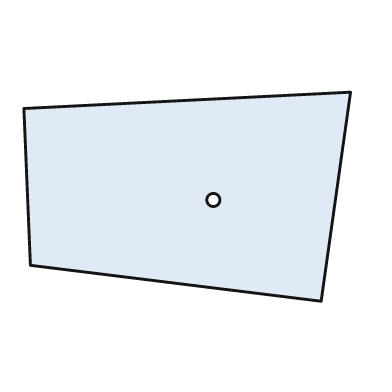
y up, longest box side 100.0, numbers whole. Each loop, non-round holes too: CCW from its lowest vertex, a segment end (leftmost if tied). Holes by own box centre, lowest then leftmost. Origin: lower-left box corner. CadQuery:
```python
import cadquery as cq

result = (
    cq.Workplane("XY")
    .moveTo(91.0, 0.0)
    .lineTo(100.0, 64.0)
    .lineTo(0.0, 59.0)
    .lineTo(2.0, 11.0)
    .close()
    .moveTo(58.0, 31.0)
    .circle(2.0)
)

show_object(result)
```